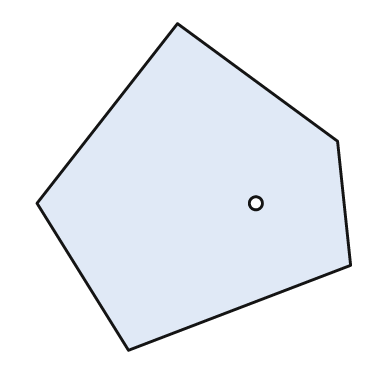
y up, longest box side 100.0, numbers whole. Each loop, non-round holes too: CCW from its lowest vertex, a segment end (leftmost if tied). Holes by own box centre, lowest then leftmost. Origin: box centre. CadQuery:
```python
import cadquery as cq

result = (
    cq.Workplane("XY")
    .moveTo(-20.0, -50.0)
    .lineTo(48.0, -24.0)
    .lineTo(44.0, 14.0)
    .lineTo(-5.0, 50.0)
    .lineTo(-48.0, -5.0)
    .close()
    .moveTo(19.0, -5.0)
    .circle(2.0)
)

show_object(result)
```